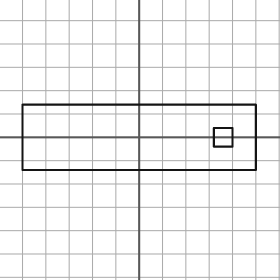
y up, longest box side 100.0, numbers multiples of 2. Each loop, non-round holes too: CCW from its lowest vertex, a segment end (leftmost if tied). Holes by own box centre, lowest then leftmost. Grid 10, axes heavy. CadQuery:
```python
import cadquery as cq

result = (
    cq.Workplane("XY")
    .moveTo(-50.0, -14.0)
    .lineTo(50.0, -14.0)
    .lineTo(50.0, 14.0)
    .lineTo(-50.0, 14.0)
    .close()
    .moveTo(32.0, -4.0)
    .lineTo(40.0, -4.0)
    .lineTo(40.0, 4.0)
    .lineTo(32.0, 4.0)
    .close()
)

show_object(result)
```